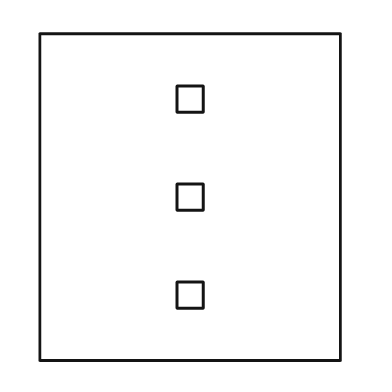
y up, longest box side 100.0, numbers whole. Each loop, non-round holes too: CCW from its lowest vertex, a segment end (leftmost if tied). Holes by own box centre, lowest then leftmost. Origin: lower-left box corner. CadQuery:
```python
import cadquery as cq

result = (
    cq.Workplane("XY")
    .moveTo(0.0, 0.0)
    .lineTo(92.0, 0.0)
    .lineTo(92.0, 100.0)
    .lineTo(0.0, 100.0)
    .close()
    .moveTo(42.0, 16.0)
    .lineTo(50.0, 16.0)
    .lineTo(50.0, 24.0)
    .lineTo(42.0, 24.0)
    .close()
    .moveTo(42.0, 46.0)
    .lineTo(50.0, 46.0)
    .lineTo(50.0, 54.0)
    .lineTo(42.0, 54.0)
    .close()
    .moveTo(42.0, 76.0)
    .lineTo(50.0, 76.0)
    .lineTo(50.0, 84.0)
    .lineTo(42.0, 84.0)
    .close()
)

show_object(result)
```